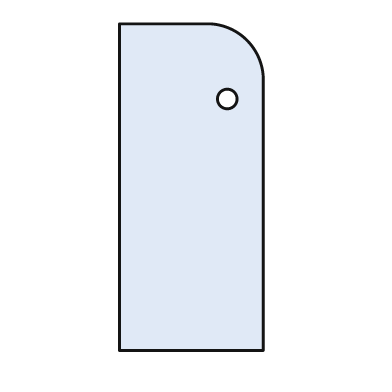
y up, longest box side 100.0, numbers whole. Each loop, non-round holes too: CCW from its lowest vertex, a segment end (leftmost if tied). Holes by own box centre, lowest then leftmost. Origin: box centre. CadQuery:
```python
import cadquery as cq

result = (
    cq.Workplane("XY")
    .moveTo(-22.0, -50.0)
    .lineTo(22.0, -50.0)
    .lineTo(22.0, 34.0)
    .threePointArc((17.0, 45.0), (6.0, 50.0))
    .lineTo(-22.0, 50.0)
    .close()
    .moveTo(11.0, 27.0)
    .circle(3.0)
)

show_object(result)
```